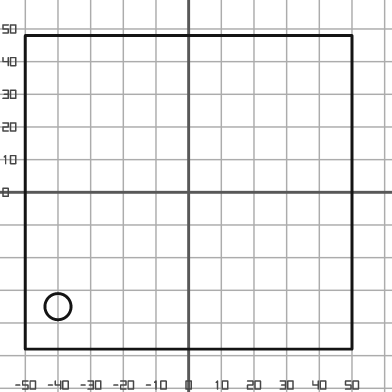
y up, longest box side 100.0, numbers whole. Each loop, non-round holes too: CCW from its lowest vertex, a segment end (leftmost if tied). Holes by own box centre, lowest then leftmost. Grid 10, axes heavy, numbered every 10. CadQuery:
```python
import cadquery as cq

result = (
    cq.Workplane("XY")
    .moveTo(-50.0, -48.0)
    .lineTo(50.0, -48.0)
    .lineTo(50.0, 48.0)
    .lineTo(-50.0, 48.0)
    .close()
    .moveTo(-40.0, -35.0)
    .circle(4.0)
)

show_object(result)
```